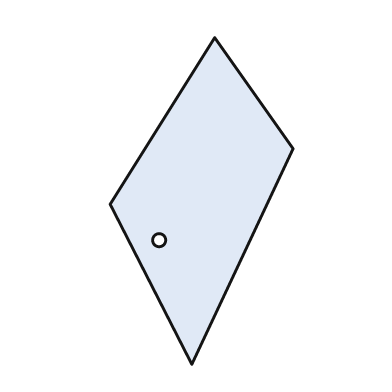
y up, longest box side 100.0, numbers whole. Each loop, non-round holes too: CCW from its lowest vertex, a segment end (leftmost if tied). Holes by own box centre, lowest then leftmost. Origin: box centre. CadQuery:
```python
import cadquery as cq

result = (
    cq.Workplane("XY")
    .moveTo(-3.0, -50.0)
    .lineTo(28.0, 16.0)
    .lineTo(4.0, 50.0)
    .lineTo(-28.0, -1.0)
    .close()
    .moveTo(-13.0, -12.0)
    .circle(2.0)
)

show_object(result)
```